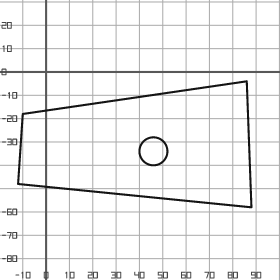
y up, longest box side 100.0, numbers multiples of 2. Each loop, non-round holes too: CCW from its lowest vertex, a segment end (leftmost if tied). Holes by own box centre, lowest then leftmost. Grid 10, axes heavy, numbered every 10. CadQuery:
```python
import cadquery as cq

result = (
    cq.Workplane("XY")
    .moveTo(88.0, -58.0)
    .lineTo(86.0, -4.0)
    .lineTo(-10.0, -18.0)
    .lineTo(-12.0, -48.0)
    .close()
    .moveTo(46.0, -34.0)
    .circle(6.0)
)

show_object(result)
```